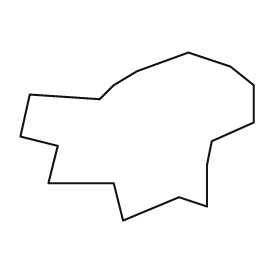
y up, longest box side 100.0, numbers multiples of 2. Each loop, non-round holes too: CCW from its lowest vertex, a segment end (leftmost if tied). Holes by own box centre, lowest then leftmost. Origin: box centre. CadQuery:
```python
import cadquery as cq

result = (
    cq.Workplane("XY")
    .moveTo(-6.0, -36.0)
    .lineTo(18.0, -26.0)
    .lineTo(30.0, -30.0)
    .lineTo(30.0, -12.0)
    .lineTo(32.0, -2.0)
    .lineTo(50.0, 6.0)
    .lineTo(50.0, 22.0)
    .lineTo(40.0, 30.0)
    .lineTo(22.0, 36.0)
    .lineTo(0.0, 28.0)
    .lineTo(-10.0, 22.0)
    .lineTo(-16.0, 16.0)
    .lineTo(-46.0, 18.0)
    .lineTo(-50.0, 0.0)
    .lineTo(-34.0, -4.0)
    .lineTo(-38.0, -20.0)
    .lineTo(-10.0, -20.0)
    .close()
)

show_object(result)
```